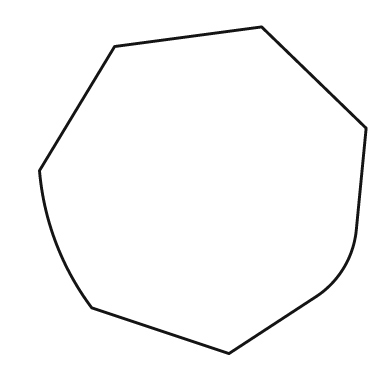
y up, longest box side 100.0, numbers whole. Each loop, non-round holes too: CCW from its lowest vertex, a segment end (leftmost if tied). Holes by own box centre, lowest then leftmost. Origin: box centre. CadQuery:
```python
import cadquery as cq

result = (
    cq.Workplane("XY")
    .moveTo(8.0, -50.0)
    .lineTo(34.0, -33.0)
    .threePointArc((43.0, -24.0), (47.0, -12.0))
    .lineTo(50.0, 19.0)
    .lineTo(18.0, 50.0)
    .lineTo(-27.0, 44.0)
    .lineTo(-50.0, 6.0)
    .threePointArc((-45.0, -16.0), (-34.0, -36.0))
    .close()
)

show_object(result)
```